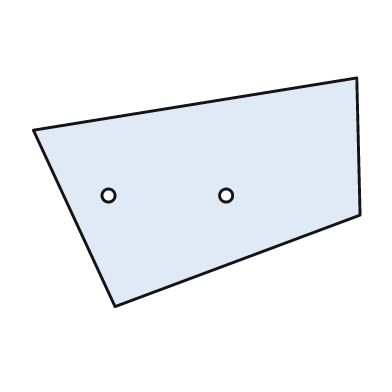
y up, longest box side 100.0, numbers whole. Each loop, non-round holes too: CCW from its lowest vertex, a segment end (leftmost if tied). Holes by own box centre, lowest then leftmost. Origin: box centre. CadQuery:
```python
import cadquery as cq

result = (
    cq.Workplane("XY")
    .moveTo(-25.0, -35.0)
    .lineTo(50.0, -7.0)
    .lineTo(49.0, 35.0)
    .lineTo(-50.0, 19.0)
    .close()
    .moveTo(-27.0, -1.0)
    .circle(2.0)
    .moveTo(9.0, -1.0)
    .circle(2.0)
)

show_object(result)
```